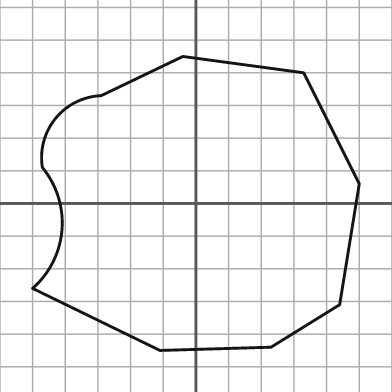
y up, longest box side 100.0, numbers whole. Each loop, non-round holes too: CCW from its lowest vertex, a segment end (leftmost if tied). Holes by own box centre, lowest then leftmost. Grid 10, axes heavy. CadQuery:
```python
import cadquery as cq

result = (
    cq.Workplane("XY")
    .moveTo(-11.0, -45.0)
    .lineTo(23.0, -44.0)
    .lineTo(44.0, -31.0)
    .lineTo(50.0, 6.0)
    .lineTo(33.0, 40.0)
    .lineTo(-4.0, 45.0)
    .lineTo(-29.0, 33.0)
    .threePointArc((-43.0, 26.0), (-47.0, 11.0))
    .threePointArc((-41.0, -8.0), (-50.0, -26.0))
    .close()
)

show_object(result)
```